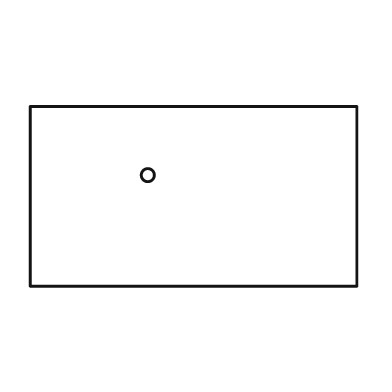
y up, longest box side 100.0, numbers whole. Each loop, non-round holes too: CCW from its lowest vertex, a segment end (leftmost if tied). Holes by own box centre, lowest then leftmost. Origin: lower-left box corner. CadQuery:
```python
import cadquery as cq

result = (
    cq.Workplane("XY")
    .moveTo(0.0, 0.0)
    .lineTo(100.0, 0.0)
    .lineTo(100.0, 55.0)
    .lineTo(0.0, 55.0)
    .close()
    .moveTo(36.0, 34.0)
    .circle(2.0)
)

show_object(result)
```